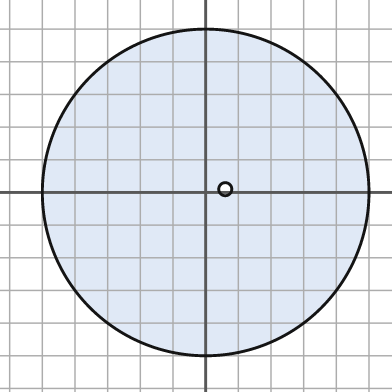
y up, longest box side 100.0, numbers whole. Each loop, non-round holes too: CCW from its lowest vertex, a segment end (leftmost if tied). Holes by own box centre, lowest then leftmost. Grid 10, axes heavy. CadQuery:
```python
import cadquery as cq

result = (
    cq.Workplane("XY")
    .moveTo(0.0, 0.0)
    .circle(50.0)
    .moveTo(6.0, 1.0)
    .circle(2.0)
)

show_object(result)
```